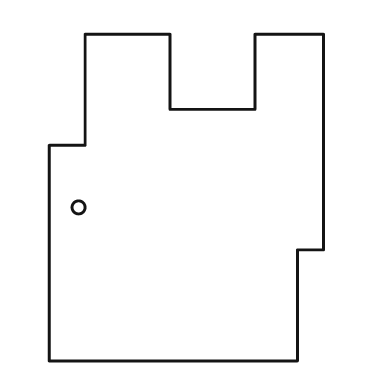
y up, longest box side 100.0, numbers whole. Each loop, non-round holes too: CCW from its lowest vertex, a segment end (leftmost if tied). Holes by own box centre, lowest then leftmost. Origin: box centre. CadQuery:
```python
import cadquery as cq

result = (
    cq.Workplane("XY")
    .moveTo(-42.0, -50.0)
    .lineTo(34.0, -50.0)
    .lineTo(34.0, -16.0)
    .lineTo(42.0, -16.0)
    .lineTo(42.0, 50.0)
    .lineTo(21.0, 50.0)
    .lineTo(21.0, 27.0)
    .lineTo(-5.0, 27.0)
    .lineTo(-5.0, 50.0)
    .lineTo(-31.0, 50.0)
    .lineTo(-31.0, 16.0)
    .lineTo(-42.0, 16.0)
    .close()
    .moveTo(-33.0, -3.0)
    .circle(2.0)
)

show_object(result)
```